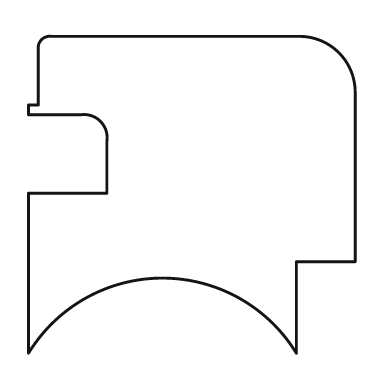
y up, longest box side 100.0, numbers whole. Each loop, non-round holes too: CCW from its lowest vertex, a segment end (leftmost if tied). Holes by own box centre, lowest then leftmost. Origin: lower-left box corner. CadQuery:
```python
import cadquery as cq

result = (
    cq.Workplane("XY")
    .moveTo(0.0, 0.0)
    .threePointArc((41.0, 23.0), (82.0, 0.0))
    .lineTo(82.0, 28.0)
    .lineTo(100.0, 28.0)
    .lineTo(100.0, 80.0)
    .threePointArc((95.0, 92.0), (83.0, 97.0))
    .lineTo(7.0, 97.0)
    .threePointArc((4.0, 96.0), (3.0, 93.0))
    .lineTo(3.0, 76.0)
    .lineTo(0.0, 76.0)
    .lineTo(0.0, 73.0)
    .lineTo(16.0, 73.0)
    .threePointArc((22.0, 71.0), (24.0, 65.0))
    .lineTo(24.0, 49.0)
    .lineTo(0.0, 49.0)
    .close()
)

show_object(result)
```